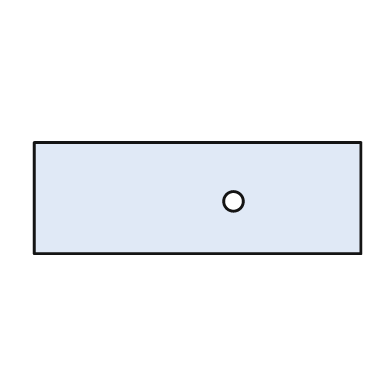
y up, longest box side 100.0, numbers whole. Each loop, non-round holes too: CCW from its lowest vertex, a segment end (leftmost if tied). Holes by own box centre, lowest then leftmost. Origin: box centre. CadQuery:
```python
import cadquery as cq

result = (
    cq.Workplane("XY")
    .moveTo(-50.0, -17.0)
    .lineTo(50.0, -17.0)
    .lineTo(50.0, 17.0)
    .lineTo(-50.0, 17.0)
    .close()
    .moveTo(11.0, -1.0)
    .circle(3.0)
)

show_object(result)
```